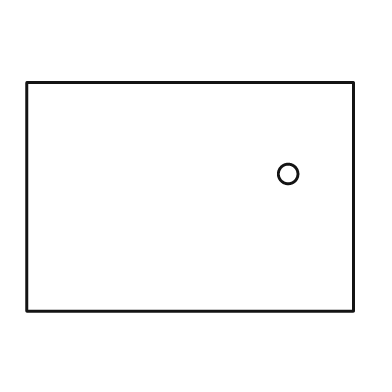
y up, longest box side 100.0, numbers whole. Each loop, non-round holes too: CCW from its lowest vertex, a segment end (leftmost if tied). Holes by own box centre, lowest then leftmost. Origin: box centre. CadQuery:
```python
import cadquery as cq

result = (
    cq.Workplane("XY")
    .moveTo(-50.0, -35.0)
    .lineTo(50.0, -35.0)
    .lineTo(50.0, 35.0)
    .lineTo(-50.0, 35.0)
    .close()
    .moveTo(30.0, 7.0)
    .circle(3.0)
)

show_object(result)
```